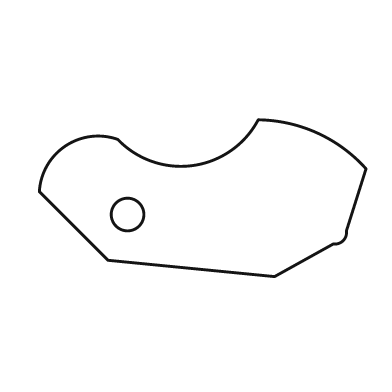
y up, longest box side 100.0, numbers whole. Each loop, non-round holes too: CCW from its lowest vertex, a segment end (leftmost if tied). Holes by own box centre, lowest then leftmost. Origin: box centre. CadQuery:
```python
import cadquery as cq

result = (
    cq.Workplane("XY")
    .moveTo(22.0, -24.0)
    .lineTo(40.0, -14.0)
    .threePointArc((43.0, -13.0), (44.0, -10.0))
    .lineTo(50.0, 9.0)
    .threePointArc((35.0, 20.0), (17.0, 24.0))
    .threePointArc((-3.0, 10.0), (-26.0, 18.0))
    .threePointArc((-42.0, 16.0), (-50.0, 2.0))
    .lineTo(-29.0, -19.0)
    .close()
    .moveTo(-23.0, -5.0)
    .circle(5.0)
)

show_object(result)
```